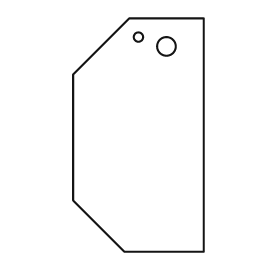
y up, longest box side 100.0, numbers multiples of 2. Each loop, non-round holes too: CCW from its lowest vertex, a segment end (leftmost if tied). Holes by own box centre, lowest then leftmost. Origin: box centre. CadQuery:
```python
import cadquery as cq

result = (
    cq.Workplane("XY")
    .moveTo(-6.0, -50.0)
    .lineTo(28.0, -50.0)
    .lineTo(28.0, 50.0)
    .lineTo(-4.0, 50.0)
    .lineTo(-28.0, 26.0)
    .lineTo(-28.0, -28.0)
    .close()
    .moveTo(12.0, 38.0)
    .circle(4.0)
    .moveTo(0.0, 42.0)
    .circle(2.0)
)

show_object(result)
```